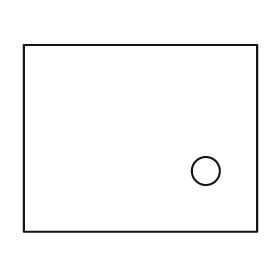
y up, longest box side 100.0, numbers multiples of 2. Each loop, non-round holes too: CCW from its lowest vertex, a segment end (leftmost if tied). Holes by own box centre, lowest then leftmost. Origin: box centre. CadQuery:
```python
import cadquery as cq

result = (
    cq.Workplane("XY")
    .moveTo(-50.0, -40.0)
    .lineTo(50.0, -40.0)
    .lineTo(50.0, 40.0)
    .lineTo(-50.0, 40.0)
    .close()
    .moveTo(28.0, -14.0)
    .circle(6.0)
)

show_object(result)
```